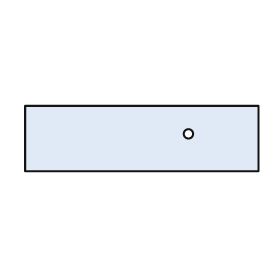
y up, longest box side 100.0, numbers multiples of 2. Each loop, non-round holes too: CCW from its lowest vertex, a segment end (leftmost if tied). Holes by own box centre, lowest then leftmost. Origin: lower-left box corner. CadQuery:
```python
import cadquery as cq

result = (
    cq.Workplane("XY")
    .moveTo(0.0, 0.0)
    .lineTo(100.0, 0.0)
    .lineTo(100.0, 28.0)
    .lineTo(0.0, 28.0)
    .close()
    .moveTo(70.0, 16.0)
    .circle(2.0)
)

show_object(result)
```